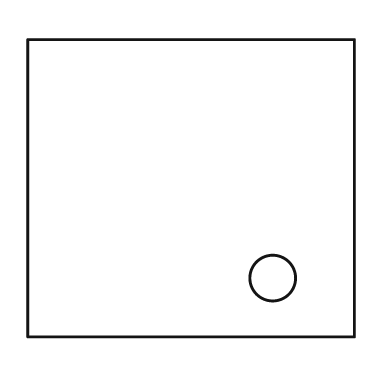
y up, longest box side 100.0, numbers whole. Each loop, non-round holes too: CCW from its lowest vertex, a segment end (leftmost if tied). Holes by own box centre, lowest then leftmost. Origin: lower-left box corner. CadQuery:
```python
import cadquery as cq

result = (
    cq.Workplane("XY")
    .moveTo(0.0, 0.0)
    .lineTo(100.0, 0.0)
    .lineTo(100.0, 91.0)
    .lineTo(0.0, 91.0)
    .close()
    .moveTo(75.0, 18.0)
    .circle(7.0)
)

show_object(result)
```